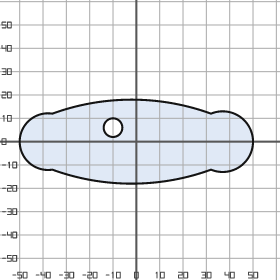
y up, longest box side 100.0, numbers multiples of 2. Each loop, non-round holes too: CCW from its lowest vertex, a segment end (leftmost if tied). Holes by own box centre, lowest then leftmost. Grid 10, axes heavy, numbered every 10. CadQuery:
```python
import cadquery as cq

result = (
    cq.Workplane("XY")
    .moveTo(-36.0, -12.0)
    .threePointArc((-2.0, -18.0), (32.0, -12.0))
    .threePointArc((50.0, 0.0), (32.0, 12.0))
    .threePointArc((-2.0, 18.0), (-36.0, 12.0))
    .threePointArc((-50.0, 0.0), (-36.0, -12.0))
    .close()
    .moveTo(-10.0, 6.0)
    .circle(4.0)
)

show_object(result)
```